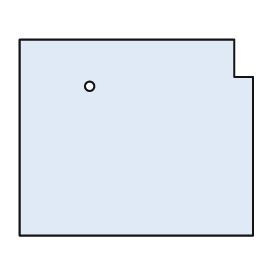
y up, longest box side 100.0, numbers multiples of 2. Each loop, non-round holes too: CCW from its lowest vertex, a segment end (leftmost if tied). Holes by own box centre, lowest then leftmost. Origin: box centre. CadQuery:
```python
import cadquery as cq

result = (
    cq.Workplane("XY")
    .moveTo(-50.0, -42.0)
    .lineTo(50.0, -42.0)
    .lineTo(50.0, 26.0)
    .lineTo(42.0, 26.0)
    .lineTo(42.0, 42.0)
    .lineTo(-50.0, 42.0)
    .close()
    .moveTo(-20.0, 22.0)
    .circle(2.0)
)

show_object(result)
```